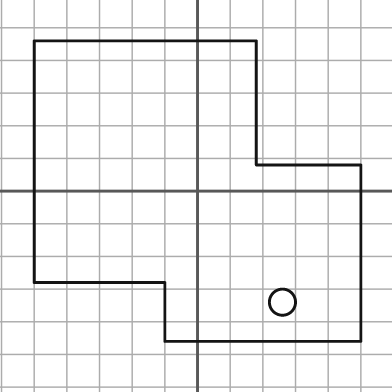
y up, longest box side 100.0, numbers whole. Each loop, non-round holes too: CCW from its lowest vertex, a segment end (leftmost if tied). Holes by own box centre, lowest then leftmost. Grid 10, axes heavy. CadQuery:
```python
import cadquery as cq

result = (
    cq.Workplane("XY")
    .moveTo(-10.0, -46.0)
    .lineTo(50.0, -46.0)
    .lineTo(50.0, 8.0)
    .lineTo(18.0, 8.0)
    .lineTo(18.0, 46.0)
    .lineTo(-50.0, 46.0)
    .lineTo(-50.0, -28.0)
    .lineTo(-10.0, -28.0)
    .close()
    .moveTo(26.0, -34.0)
    .circle(4.0)
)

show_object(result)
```